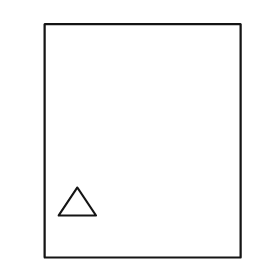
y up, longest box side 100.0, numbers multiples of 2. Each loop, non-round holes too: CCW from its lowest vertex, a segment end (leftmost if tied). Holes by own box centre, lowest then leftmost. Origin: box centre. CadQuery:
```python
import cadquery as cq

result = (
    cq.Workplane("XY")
    .moveTo(-42.0, -50.0)
    .lineTo(42.0, -50.0)
    .lineTo(42.0, 50.0)
    .lineTo(-42.0, 50.0)
    .close()
    .moveTo(-36.0, -32.0)
    .lineTo(-20.0, -32.0)
    .lineTo(-28.0, -20.0)
    .close()
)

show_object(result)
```